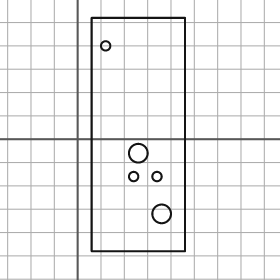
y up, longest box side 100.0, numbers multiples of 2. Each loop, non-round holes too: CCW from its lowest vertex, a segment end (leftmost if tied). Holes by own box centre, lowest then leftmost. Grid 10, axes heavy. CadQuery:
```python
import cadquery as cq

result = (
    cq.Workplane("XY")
    .moveTo(6.0, -48.0)
    .lineTo(46.0, -48.0)
    .lineTo(46.0, 52.0)
    .lineTo(6.0, 52.0)
    .close()
    .moveTo(36.0, -32.0)
    .circle(4.0)
    .moveTo(24.0, -16.0)
    .circle(2.0)
    .moveTo(34.0, -16.0)
    .circle(2.0)
    .moveTo(26.0, -6.0)
    .circle(4.0)
    .moveTo(12.0, 40.0)
    .circle(2.0)
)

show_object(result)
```